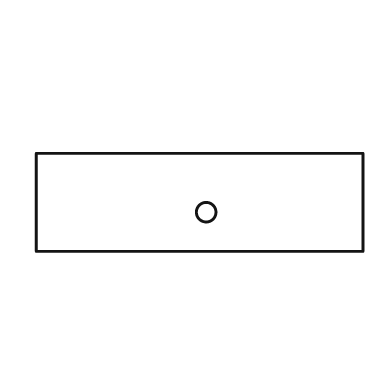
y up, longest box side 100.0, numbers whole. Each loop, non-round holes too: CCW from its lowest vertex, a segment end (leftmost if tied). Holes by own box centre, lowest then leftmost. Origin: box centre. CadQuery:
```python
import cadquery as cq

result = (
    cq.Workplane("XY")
    .moveTo(-50.0, -15.0)
    .lineTo(50.0, -15.0)
    .lineTo(50.0, 15.0)
    .lineTo(-50.0, 15.0)
    .close()
    .moveTo(2.0, -3.0)
    .circle(3.0)
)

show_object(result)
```